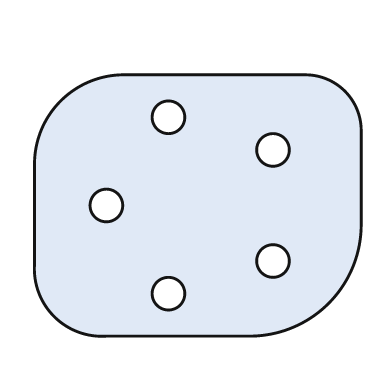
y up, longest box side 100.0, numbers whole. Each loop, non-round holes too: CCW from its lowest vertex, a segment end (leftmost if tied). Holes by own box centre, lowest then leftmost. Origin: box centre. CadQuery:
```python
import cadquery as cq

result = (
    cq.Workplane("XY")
    .moveTo(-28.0, -40.0)
    .lineTo(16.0, -40.0)
    .threePointArc((40.0, -30.0), (50.0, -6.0))
    .lineTo(50.0, 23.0)
    .threePointArc((45.0, 35.0), (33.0, 40.0))
    .lineTo(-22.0, 40.0)
    .threePointArc((-42.0, 32.0), (-50.0, 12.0))
    .lineTo(-50.0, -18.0)
    .threePointArc((-44.0, -34.0), (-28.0, -40.0))
    .close()
    .moveTo(-9.0, -27.0)
    .circle(5.0)
    .moveTo(23.0, -17.0)
    .circle(5.0)
    .moveTo(-28.0, 0.0)
    .circle(5.0)
    .moveTo(23.0, 17.0)
    .circle(5.0)
    .moveTo(-9.0, 27.0)
    .circle(5.0)
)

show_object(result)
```